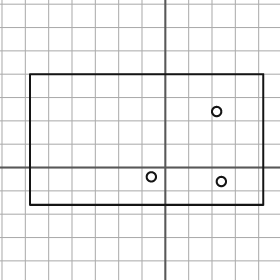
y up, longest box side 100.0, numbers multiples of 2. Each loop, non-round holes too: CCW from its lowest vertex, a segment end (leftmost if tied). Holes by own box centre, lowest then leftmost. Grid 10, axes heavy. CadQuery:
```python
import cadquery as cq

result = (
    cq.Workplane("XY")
    .moveTo(-58.0, -16.0)
    .lineTo(42.0, -16.0)
    .lineTo(42.0, 40.0)
    .lineTo(-58.0, 40.0)
    .close()
    .moveTo(24.0, -6.0)
    .circle(2.0)
    .moveTo(-6.0, -4.0)
    .circle(2.0)
    .moveTo(22.0, 24.0)
    .circle(2.0)
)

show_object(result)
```